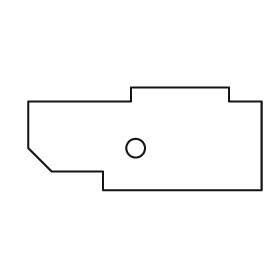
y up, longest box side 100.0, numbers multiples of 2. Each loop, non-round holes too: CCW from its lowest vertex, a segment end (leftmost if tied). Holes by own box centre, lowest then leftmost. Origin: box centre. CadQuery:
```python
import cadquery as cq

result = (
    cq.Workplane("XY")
    .moveTo(-18.0, -22.0)
    .lineTo(50.0, -22.0)
    .lineTo(50.0, 16.0)
    .lineTo(36.0, 16.0)
    .lineTo(36.0, 22.0)
    .lineTo(-6.0, 22.0)
    .lineTo(-6.0, 16.0)
    .lineTo(-50.0, 16.0)
    .lineTo(-50.0, -4.0)
    .lineTo(-40.0, -14.0)
    .lineTo(-18.0, -14.0)
    .close()
    .moveTo(-4.0, -4.0)
    .circle(4.0)
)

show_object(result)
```